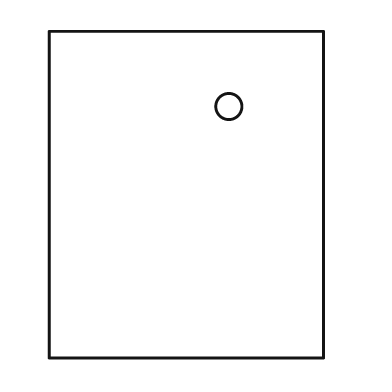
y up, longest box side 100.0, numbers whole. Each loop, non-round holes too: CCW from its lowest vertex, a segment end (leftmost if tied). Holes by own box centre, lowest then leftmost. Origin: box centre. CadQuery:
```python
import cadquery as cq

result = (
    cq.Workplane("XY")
    .moveTo(-42.0, -50.0)
    .lineTo(42.0, -50.0)
    .lineTo(42.0, 50.0)
    .lineTo(-42.0, 50.0)
    .close()
    .moveTo(13.0, 27.0)
    .circle(4.0)
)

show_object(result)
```